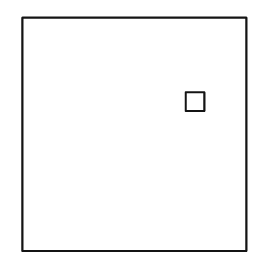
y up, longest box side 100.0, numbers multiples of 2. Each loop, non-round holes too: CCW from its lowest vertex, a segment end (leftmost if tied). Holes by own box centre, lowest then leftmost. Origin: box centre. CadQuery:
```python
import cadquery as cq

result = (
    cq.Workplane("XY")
    .moveTo(-48.0, -50.0)
    .lineTo(48.0, -50.0)
    .lineTo(48.0, 50.0)
    .lineTo(-48.0, 50.0)
    .close()
    .moveTo(22.0, 10.0)
    .lineTo(30.0, 10.0)
    .lineTo(30.0, 18.0)
    .lineTo(22.0, 18.0)
    .close()
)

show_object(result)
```